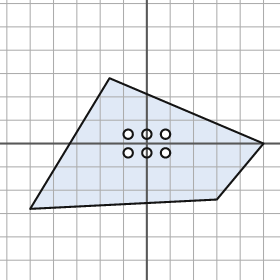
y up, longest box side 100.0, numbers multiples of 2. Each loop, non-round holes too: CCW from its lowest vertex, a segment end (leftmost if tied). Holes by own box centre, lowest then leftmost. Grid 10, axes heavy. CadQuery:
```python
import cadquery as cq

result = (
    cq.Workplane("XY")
    .moveTo(-50.0, -28.0)
    .lineTo(30.0, -24.0)
    .lineTo(50.0, 0.0)
    .lineTo(-16.0, 28.0)
    .close()
    .moveTo(-8.0, -4.0)
    .circle(2.0)
    .moveTo(0.0, -4.0)
    .circle(2.0)
    .moveTo(8.0, -4.0)
    .circle(2.0)
    .moveTo(-8.0, 4.0)
    .circle(2.0)
    .moveTo(0.0, 4.0)
    .circle(2.0)
    .moveTo(8.0, 4.0)
    .circle(2.0)
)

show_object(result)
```